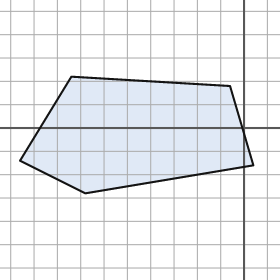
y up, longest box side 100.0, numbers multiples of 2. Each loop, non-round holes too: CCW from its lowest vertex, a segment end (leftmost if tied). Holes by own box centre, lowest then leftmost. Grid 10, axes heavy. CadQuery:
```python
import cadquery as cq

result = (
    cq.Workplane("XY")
    .moveTo(-68.0, -28.0)
    .lineTo(4.0, -16.0)
    .lineTo(-6.0, 18.0)
    .lineTo(-74.0, 22.0)
    .lineTo(-96.0, -14.0)
    .close()
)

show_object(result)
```